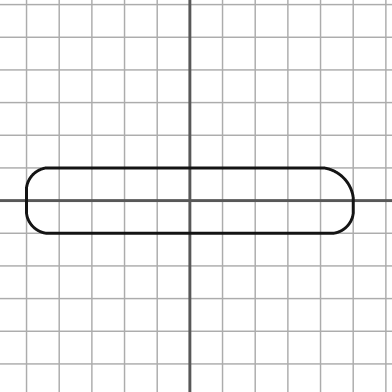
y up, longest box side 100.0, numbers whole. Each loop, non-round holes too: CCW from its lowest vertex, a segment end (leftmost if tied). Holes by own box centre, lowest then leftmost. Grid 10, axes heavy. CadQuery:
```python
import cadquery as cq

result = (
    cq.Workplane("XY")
    .moveTo(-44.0, -10.0)
    .lineTo(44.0, -10.0)
    .threePointArc((48.0, -8.0), (50.0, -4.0))
    .lineTo(50.0, 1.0)
    .threePointArc((47.0, 7.0), (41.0, 10.0))
    .lineTo(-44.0, 10.0)
    .threePointArc((-48.0, 8.0), (-50.0, 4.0))
    .lineTo(-50.0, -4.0)
    .threePointArc((-48.0, -8.0), (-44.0, -10.0))
    .close()
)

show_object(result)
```